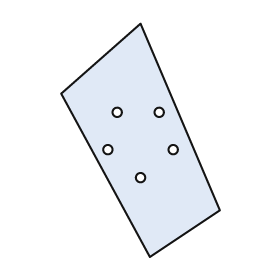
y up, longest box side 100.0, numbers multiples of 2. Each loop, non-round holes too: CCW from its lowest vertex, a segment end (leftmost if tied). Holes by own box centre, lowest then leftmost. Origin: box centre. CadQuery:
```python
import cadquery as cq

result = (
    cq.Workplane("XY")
    .moveTo(4.0, -50.0)
    .lineTo(34.0, -30.0)
    .lineTo(0.0, 50.0)
    .lineTo(-34.0, 20.0)
    .close()
    .moveTo(0.0, -16.0)
    .circle(2.0)
    .moveTo(-14.0, -4.0)
    .circle(2.0)
    .moveTo(14.0, -4.0)
    .circle(2.0)
    .moveTo(-10.0, 12.0)
    .circle(2.0)
    .moveTo(8.0, 12.0)
    .circle(2.0)
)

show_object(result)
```